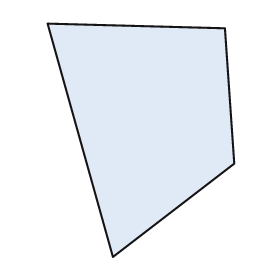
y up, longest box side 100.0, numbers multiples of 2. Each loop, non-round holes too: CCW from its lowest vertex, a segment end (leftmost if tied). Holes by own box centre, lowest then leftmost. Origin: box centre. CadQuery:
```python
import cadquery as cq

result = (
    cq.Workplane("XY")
    .moveTo(-12.0, -50.0)
    .lineTo(40.0, -10.0)
    .lineTo(36.0, 48.0)
    .lineTo(-40.0, 50.0)
    .close()
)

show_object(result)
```